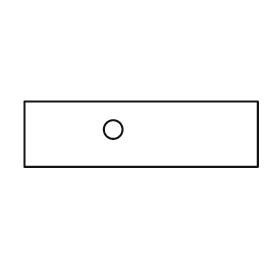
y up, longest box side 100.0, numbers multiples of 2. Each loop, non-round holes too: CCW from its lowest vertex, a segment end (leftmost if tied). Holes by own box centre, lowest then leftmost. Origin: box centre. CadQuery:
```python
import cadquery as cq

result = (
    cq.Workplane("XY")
    .moveTo(-50.0, -14.0)
    .lineTo(50.0, -14.0)
    .lineTo(50.0, 14.0)
    .lineTo(-50.0, 14.0)
    .close()
    .moveTo(-12.0, 2.0)
    .circle(4.0)
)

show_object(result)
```